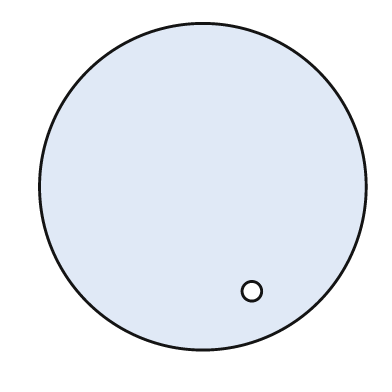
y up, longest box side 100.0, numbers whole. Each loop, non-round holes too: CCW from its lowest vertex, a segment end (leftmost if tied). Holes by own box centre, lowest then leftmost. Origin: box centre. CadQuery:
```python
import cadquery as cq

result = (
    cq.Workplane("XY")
    .moveTo(0.0, 0.0)
    .circle(50.0)
    .moveTo(15.0, -32.0)
    .circle(3.0)
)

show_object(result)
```